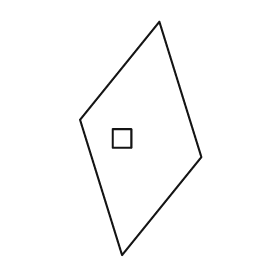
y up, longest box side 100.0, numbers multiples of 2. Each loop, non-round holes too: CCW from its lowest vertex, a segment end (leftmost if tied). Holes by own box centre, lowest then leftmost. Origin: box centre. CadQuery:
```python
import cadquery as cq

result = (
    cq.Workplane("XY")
    .moveTo(-8.0, -50.0)
    .lineTo(26.0, -8.0)
    .lineTo(8.0, 50.0)
    .lineTo(-26.0, 8.0)
    .close()
    .moveTo(-12.0, -4.0)
    .lineTo(-4.0, -4.0)
    .lineTo(-4.0, 4.0)
    .lineTo(-12.0, 4.0)
    .close()
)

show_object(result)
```